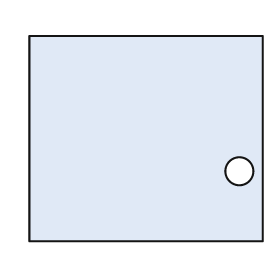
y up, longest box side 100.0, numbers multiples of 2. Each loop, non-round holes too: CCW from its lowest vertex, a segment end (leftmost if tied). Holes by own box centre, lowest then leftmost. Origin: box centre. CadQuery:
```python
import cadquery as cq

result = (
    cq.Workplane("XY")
    .moveTo(-50.0, -44.0)
    .lineTo(50.0, -44.0)
    .lineTo(50.0, 44.0)
    .lineTo(-50.0, 44.0)
    .close()
    .moveTo(40.0, -14.0)
    .circle(6.0)
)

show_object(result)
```